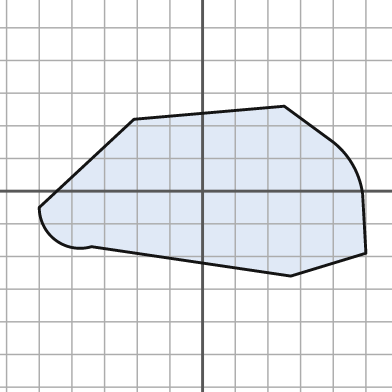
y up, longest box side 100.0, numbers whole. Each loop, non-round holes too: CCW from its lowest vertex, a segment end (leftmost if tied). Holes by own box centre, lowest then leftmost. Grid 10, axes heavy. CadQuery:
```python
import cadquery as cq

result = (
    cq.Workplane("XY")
    .moveTo(27.0, -26.0)
    .lineTo(50.0, -19.0)
    .lineTo(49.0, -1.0)
    .threePointArc((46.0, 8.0), (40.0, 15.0))
    .lineTo(25.0, 26.0)
    .lineTo(-21.0, 22.0)
    .lineTo(-50.0, -5.0)
    .threePointArc((-45.0, -15.0), (-34.0, -17.0))
    .close()
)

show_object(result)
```